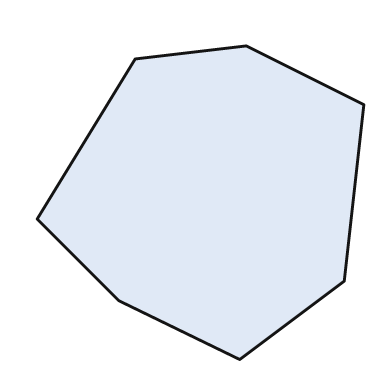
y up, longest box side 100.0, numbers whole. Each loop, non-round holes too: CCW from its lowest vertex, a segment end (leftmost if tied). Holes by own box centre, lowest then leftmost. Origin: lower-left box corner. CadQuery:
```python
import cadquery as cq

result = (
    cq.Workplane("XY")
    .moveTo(62.0, 0.0)
    .lineTo(94.0, 24.0)
    .lineTo(100.0, 78.0)
    .lineTo(64.0, 96.0)
    .lineTo(30.0, 92.0)
    .lineTo(0.0, 43.0)
    .lineTo(25.0, 18.0)
    .close()
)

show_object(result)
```